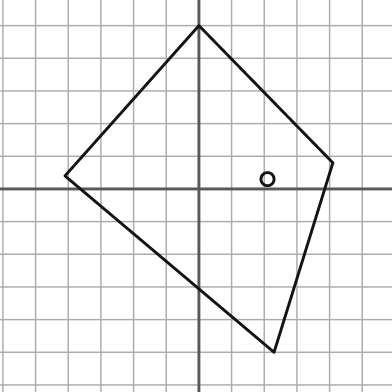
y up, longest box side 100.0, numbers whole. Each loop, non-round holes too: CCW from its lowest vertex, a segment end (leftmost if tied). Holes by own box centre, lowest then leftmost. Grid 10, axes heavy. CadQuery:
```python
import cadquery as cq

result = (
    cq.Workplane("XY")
    .moveTo(23.0, -50.0)
    .lineTo(41.0, 8.0)
    .lineTo(0.0, 50.0)
    .lineTo(-41.0, 4.0)
    .close()
    .moveTo(21.0, 3.0)
    .circle(2.0)
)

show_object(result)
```